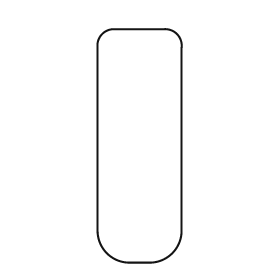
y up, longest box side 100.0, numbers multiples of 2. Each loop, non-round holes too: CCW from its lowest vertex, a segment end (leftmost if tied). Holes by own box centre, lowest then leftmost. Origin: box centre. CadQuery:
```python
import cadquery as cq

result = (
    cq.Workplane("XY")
    .moveTo(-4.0, -50.0)
    .lineTo(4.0, -50.0)
    .threePointArc((14.0, -46.0), (18.0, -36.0))
    .lineTo(18.0, 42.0)
    .threePointArc((16.0, 48.0), (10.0, 50.0))
    .lineTo(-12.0, 50.0)
    .threePointArc((-16.0, 48.0), (-18.0, 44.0))
    .lineTo(-18.0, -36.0)
    .threePointArc((-14.0, -46.0), (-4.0, -50.0))
    .close()
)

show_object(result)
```